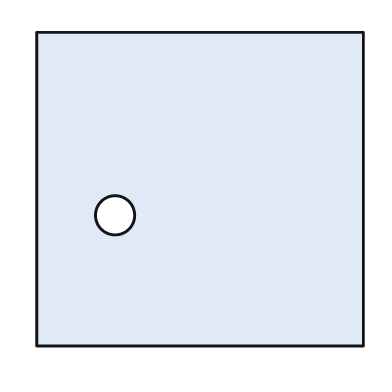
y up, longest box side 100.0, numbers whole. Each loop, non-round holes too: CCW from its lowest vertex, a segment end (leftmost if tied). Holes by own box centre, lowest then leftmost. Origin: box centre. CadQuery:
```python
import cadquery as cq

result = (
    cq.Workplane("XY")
    .moveTo(-50.0, -48.0)
    .lineTo(50.0, -48.0)
    .lineTo(50.0, 48.0)
    .lineTo(-50.0, 48.0)
    .close()
    .moveTo(-26.0, -8.0)
    .circle(6.0)
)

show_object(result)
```